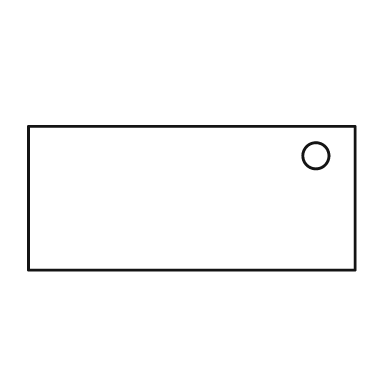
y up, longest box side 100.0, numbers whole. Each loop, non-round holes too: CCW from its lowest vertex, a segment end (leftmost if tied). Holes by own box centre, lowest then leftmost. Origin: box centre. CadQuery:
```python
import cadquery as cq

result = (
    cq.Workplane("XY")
    .moveTo(-50.0, -22.0)
    .lineTo(50.0, -22.0)
    .lineTo(50.0, 22.0)
    .lineTo(-50.0, 22.0)
    .close()
    .moveTo(38.0, 13.0)
    .circle(4.0)
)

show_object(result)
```